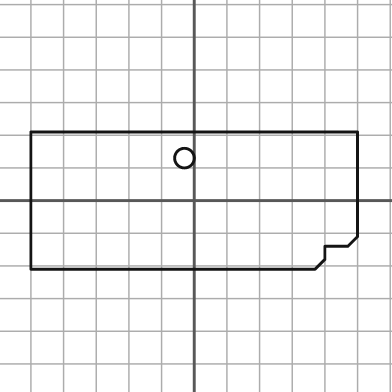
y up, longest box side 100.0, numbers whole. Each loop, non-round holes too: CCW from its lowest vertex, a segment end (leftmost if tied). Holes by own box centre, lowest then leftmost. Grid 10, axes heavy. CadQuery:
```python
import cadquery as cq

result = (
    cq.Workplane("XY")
    .moveTo(-50.0, -21.0)
    .lineTo(37.0, -21.0)
    .lineTo(40.0, -18.0)
    .lineTo(40.0, -14.0)
    .lineTo(47.0, -14.0)
    .lineTo(50.0, -11.0)
    .lineTo(50.0, 21.0)
    .lineTo(-50.0, 21.0)
    .close()
    .moveTo(-3.0, 13.0)
    .circle(3.0)
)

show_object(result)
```